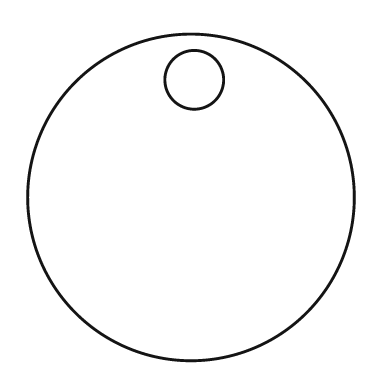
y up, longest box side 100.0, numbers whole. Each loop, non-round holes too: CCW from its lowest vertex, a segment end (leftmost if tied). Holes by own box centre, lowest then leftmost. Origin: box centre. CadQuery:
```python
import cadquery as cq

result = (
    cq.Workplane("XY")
    .moveTo(0.0, 0.0)
    .circle(50.0)
    .moveTo(1.0, 36.0)
    .circle(9.0)
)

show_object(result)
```